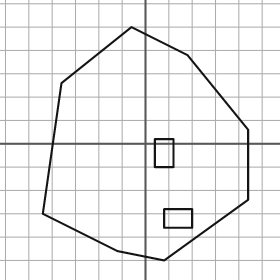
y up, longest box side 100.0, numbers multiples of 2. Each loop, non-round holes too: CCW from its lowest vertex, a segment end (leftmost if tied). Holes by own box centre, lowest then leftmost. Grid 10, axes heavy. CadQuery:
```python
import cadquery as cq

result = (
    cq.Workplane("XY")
    .moveTo(8.0, -50.0)
    .lineTo(44.0, -24.0)
    .lineTo(44.0, 6.0)
    .lineTo(18.0, 38.0)
    .lineTo(-6.0, 50.0)
    .lineTo(-36.0, 26.0)
    .lineTo(-44.0, -30.0)
    .lineTo(-12.0, -46.0)
    .close()
    .moveTo(8.0, -36.0)
    .lineTo(20.0, -36.0)
    .lineTo(20.0, -28.0)
    .lineTo(8.0, -28.0)
    .close()
    .moveTo(4.0, -10.0)
    .lineTo(12.0, -10.0)
    .lineTo(12.0, 2.0)
    .lineTo(4.0, 2.0)
    .close()
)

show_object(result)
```